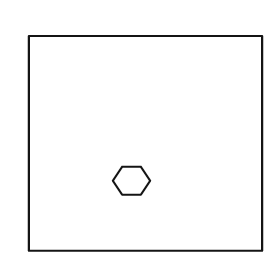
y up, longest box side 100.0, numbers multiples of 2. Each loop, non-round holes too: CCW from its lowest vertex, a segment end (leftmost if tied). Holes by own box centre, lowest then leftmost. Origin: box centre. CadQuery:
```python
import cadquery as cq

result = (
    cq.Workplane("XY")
    .moveTo(-50.0, -46.0)
    .lineTo(50.0, -46.0)
    .lineTo(50.0, 46.0)
    .lineTo(-50.0, 46.0)
    .close()
    .moveTo(-10.0, -22.0)
    .lineTo(-2.0, -22.0)
    .lineTo(2.0, -16.0)
    .lineTo(-2.0, -10.0)
    .lineTo(-10.0, -10.0)
    .lineTo(-14.0, -16.0)
    .close()
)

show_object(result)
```